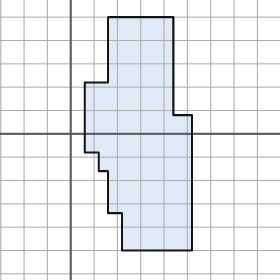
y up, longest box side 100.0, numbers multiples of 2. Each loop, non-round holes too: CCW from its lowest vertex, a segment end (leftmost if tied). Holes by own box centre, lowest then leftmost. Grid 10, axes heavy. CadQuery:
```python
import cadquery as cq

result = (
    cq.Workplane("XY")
    .moveTo(22.0, -50.0)
    .lineTo(52.0, -50.0)
    .lineTo(52.0, 8.0)
    .lineTo(44.0, 8.0)
    .lineTo(44.0, 50.0)
    .lineTo(16.0, 50.0)
    .lineTo(16.0, 22.0)
    .lineTo(6.0, 22.0)
    .lineTo(6.0, -8.0)
    .lineTo(12.0, -8.0)
    .lineTo(12.0, -16.0)
    .lineTo(16.0, -16.0)
    .lineTo(16.0, -34.0)
    .lineTo(22.0, -34.0)
    .close()
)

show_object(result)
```